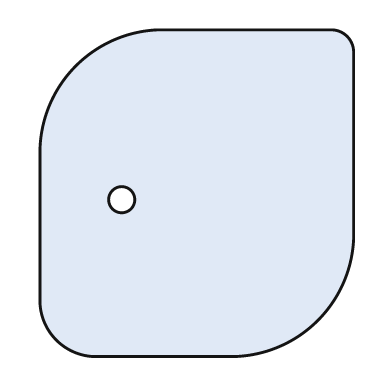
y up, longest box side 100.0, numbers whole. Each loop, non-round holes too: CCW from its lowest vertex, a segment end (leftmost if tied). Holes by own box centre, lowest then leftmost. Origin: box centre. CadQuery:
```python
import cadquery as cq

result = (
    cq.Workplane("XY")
    .moveTo(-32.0, -50.0)
    .lineTo(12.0, -50.0)
    .threePointArc((37.0, -39.0), (48.0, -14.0))
    .lineTo(48.0, 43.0)
    .threePointArc((46.0, 48.0), (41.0, 50.0))
    .lineTo(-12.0, 50.0)
    .threePointArc((-37.0, 39.0), (-48.0, 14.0))
    .lineTo(-48.0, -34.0)
    .threePointArc((-43.0, -45.0), (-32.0, -50.0))
    .close()
    .moveTo(-23.0, -2.0)
    .circle(4.0)
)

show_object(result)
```